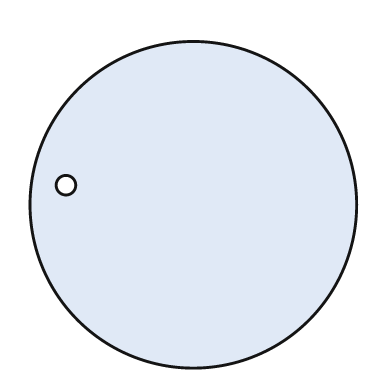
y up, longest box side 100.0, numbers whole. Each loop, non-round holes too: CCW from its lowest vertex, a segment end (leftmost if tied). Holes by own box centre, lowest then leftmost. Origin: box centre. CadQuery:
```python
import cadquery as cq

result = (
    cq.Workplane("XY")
    .moveTo(0.0, 0.0)
    .circle(50.0)
    .moveTo(-39.0, 6.0)
    .circle(3.0)
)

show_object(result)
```